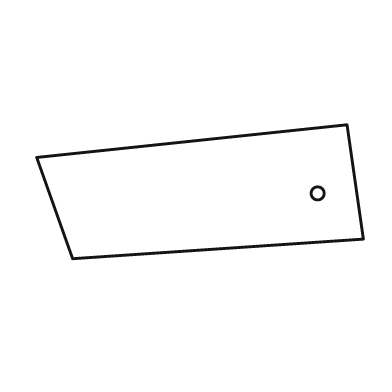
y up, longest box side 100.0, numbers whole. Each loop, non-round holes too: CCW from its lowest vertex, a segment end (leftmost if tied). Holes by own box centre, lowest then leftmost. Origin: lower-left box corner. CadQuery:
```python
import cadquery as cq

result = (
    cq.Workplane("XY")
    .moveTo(11.0, 0.0)
    .lineTo(100.0, 6.0)
    .lineTo(95.0, 41.0)
    .lineTo(0.0, 31.0)
    .close()
    .moveTo(86.0, 20.0)
    .circle(2.0)
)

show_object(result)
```